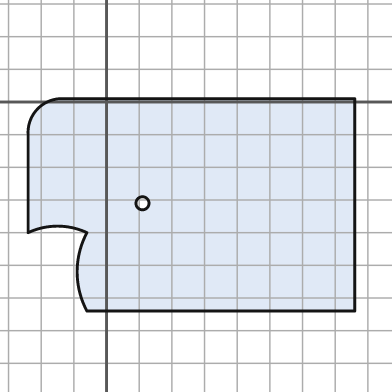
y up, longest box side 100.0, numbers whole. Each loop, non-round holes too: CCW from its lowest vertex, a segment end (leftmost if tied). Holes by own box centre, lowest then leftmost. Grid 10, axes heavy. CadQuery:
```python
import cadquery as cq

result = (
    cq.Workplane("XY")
    .moveTo(-6.0, -64.0)
    .lineTo(76.0, -64.0)
    .lineTo(76.0, 1.0)
    .lineTo(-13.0, 1.0)
    .threePointArc((-21.0, -2.0), (-24.0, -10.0))
    .lineTo(-24.0, -40.0)
    .threePointArc((-15.0, -38.0), (-6.0, -40.0))
    .threePointArc((-9.0, -52.0), (-6.0, -64.0))
    .close()
    .moveTo(11.0, -31.0)
    .circle(2.0)
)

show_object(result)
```